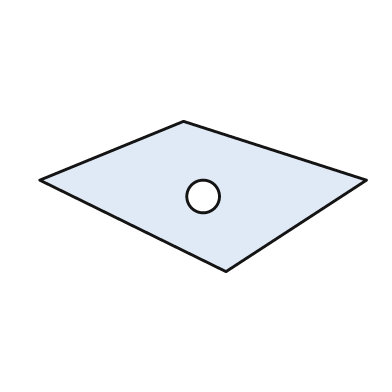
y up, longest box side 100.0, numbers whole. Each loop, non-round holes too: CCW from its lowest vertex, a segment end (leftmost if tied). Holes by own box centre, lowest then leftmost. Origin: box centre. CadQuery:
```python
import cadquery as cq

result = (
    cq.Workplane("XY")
    .moveTo(7.0, -23.0)
    .lineTo(50.0, 5.0)
    .lineTo(-6.0, 23.0)
    .lineTo(-50.0, 5.0)
    .close()
    .moveTo(0.0, 0.0)
    .circle(5.0)
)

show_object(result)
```